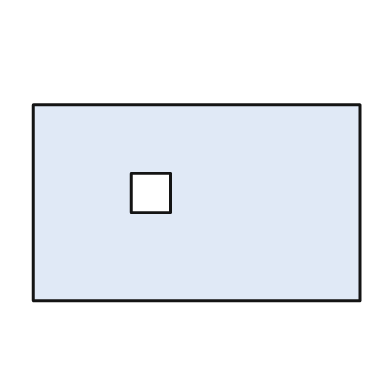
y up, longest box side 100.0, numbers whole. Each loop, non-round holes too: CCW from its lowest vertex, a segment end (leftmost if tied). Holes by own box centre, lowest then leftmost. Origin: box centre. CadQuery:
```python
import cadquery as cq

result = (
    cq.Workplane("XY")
    .moveTo(-50.0, -30.0)
    .lineTo(50.0, -30.0)
    .lineTo(50.0, 30.0)
    .lineTo(-50.0, 30.0)
    .close()
    .moveTo(-20.0, -3.0)
    .lineTo(-8.0, -3.0)
    .lineTo(-8.0, 9.0)
    .lineTo(-20.0, 9.0)
    .close()
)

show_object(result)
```